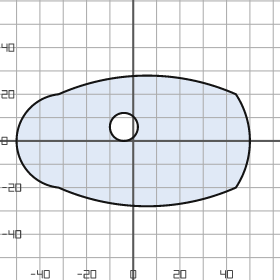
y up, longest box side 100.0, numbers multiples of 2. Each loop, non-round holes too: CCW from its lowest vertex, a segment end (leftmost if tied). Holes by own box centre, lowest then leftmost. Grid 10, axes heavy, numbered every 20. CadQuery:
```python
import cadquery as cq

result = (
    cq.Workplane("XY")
    .moveTo(-32.0, -20.0)
    .threePointArc((6.0, -28.0), (44.0, -20.0))
    .threePointArc((50.0, 0.0), (44.0, 20.0))
    .threePointArc((6.0, 28.0), (-32.0, 20.0))
    .threePointArc((-50.0, 0.0), (-32.0, -20.0))
    .close()
    .moveTo(-4.0, 6.0)
    .circle(6.0)
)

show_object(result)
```